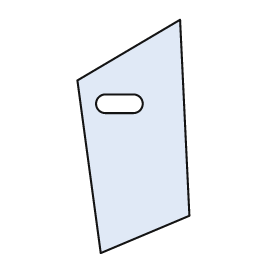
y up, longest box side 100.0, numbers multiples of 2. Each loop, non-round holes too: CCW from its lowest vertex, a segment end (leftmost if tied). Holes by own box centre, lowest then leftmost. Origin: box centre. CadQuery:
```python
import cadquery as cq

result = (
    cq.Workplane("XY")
    .moveTo(-14.0, -50.0)
    .lineTo(24.0, -34.0)
    .lineTo(20.0, 50.0)
    .lineTo(-24.0, 24.0)
    .close()
    .moveTo(-12.0, 10.0)
    .lineTo(0.0, 10.0)
    .threePointArc((4.0, 14.0), (0.0, 18.0))
    .lineTo(-12.0, 18.0)
    .threePointArc((-16.0, 14.0), (-12.0, 10.0))
    .close()
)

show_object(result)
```